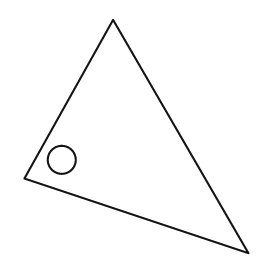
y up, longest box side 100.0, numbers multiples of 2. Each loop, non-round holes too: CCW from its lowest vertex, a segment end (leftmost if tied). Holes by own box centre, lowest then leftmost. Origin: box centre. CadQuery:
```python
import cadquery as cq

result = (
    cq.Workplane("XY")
    .moveTo(48.0, -50.0)
    .lineTo(-10.0, 50.0)
    .lineTo(-48.0, -18.0)
    .close()
    .moveTo(-32.0, -10.0)
    .circle(6.0)
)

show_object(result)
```